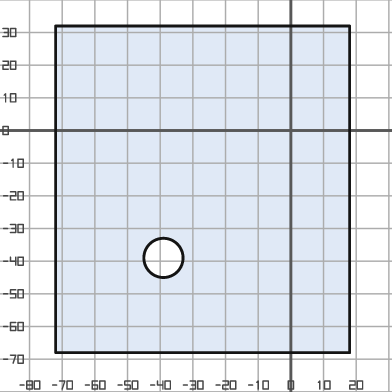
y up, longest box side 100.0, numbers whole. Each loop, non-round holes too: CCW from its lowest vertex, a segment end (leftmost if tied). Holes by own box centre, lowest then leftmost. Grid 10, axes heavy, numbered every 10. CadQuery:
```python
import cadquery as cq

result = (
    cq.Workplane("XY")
    .moveTo(-72.0, -68.0)
    .lineTo(18.0, -68.0)
    .lineTo(18.0, 32.0)
    .lineTo(-72.0, 32.0)
    .close()
    .moveTo(-39.0, -39.0)
    .circle(6.0)
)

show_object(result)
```